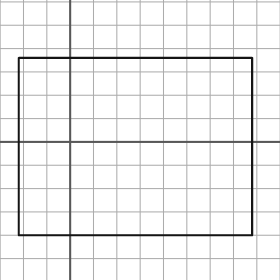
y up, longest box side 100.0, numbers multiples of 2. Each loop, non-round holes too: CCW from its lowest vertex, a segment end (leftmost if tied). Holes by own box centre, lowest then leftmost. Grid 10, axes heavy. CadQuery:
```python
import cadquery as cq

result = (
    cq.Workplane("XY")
    .moveTo(-22.0, -40.0)
    .lineTo(78.0, -40.0)
    .lineTo(78.0, 36.0)
    .lineTo(-22.0, 36.0)
    .close()
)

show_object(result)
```